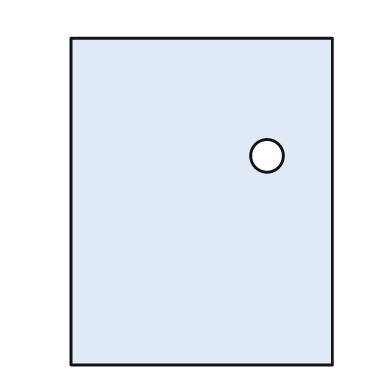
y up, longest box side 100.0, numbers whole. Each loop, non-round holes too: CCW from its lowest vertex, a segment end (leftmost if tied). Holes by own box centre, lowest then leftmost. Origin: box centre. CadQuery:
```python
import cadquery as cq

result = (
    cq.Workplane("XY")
    .moveTo(-40.0, -50.0)
    .lineTo(40.0, -50.0)
    .lineTo(40.0, 50.0)
    .lineTo(-40.0, 50.0)
    .close()
    .moveTo(20.0, 14.0)
    .circle(5.0)
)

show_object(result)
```